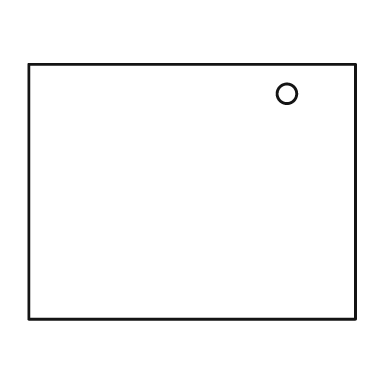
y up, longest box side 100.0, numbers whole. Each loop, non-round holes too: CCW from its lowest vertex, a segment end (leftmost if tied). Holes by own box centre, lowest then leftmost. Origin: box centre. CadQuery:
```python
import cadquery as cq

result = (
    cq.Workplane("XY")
    .moveTo(-50.0, -39.0)
    .lineTo(50.0, -39.0)
    .lineTo(50.0, 39.0)
    .lineTo(-50.0, 39.0)
    .close()
    .moveTo(29.0, 30.0)
    .circle(3.0)
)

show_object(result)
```